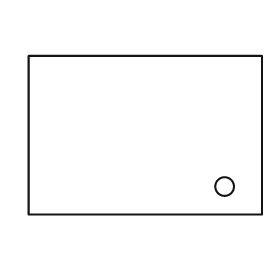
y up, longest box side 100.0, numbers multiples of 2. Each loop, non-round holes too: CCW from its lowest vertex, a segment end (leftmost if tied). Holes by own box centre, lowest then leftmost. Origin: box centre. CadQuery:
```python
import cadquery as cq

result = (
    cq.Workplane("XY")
    .moveTo(-50.0, -34.0)
    .lineTo(50.0, -34.0)
    .lineTo(50.0, 34.0)
    .lineTo(-50.0, 34.0)
    .close()
    .moveTo(34.0, -22.0)
    .circle(4.0)
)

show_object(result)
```